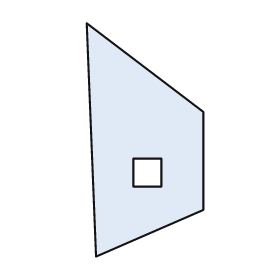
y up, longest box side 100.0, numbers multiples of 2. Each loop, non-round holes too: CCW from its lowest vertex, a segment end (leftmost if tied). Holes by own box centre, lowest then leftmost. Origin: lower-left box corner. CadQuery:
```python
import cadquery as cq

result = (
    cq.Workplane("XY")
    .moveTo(4.0, 0.0)
    .lineTo(50.0, 20.0)
    .lineTo(50.0, 62.0)
    .lineTo(0.0, 100.0)
    .close()
    .moveTo(20.0, 30.0)
    .lineTo(32.0, 30.0)
    .lineTo(32.0, 42.0)
    .lineTo(20.0, 42.0)
    .close()
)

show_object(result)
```